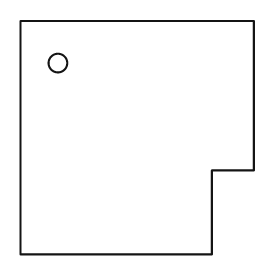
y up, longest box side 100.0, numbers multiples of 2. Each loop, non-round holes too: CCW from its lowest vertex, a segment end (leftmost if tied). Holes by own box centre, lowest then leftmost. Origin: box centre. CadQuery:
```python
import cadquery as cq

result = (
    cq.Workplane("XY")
    .moveTo(-50.0, -50.0)
    .lineTo(32.0, -50.0)
    .lineTo(32.0, -14.0)
    .lineTo(50.0, -14.0)
    .lineTo(50.0, 50.0)
    .lineTo(-50.0, 50.0)
    .close()
    .moveTo(-34.0, 32.0)
    .circle(4.0)
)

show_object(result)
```